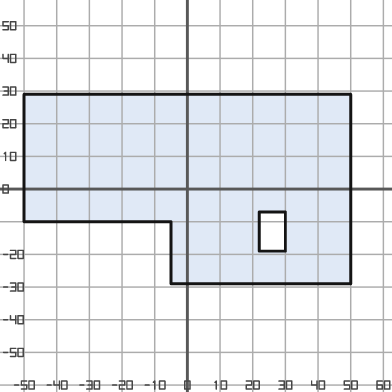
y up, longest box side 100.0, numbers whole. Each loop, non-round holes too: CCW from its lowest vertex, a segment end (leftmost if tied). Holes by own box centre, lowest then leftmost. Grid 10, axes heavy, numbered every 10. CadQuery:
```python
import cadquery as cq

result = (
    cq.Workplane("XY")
    .moveTo(-5.0, -29.0)
    .lineTo(50.0, -29.0)
    .lineTo(50.0, 29.0)
    .lineTo(-50.0, 29.0)
    .lineTo(-50.0, -10.0)
    .lineTo(-5.0, -10.0)
    .close()
    .moveTo(22.0, -19.0)
    .lineTo(30.0, -19.0)
    .lineTo(30.0, -7.0)
    .lineTo(22.0, -7.0)
    .close()
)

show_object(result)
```